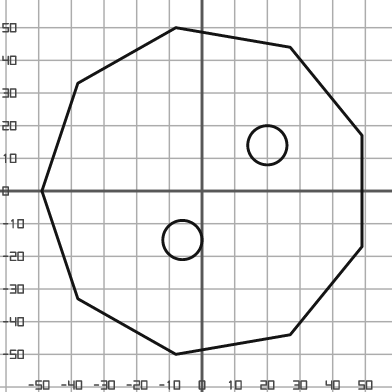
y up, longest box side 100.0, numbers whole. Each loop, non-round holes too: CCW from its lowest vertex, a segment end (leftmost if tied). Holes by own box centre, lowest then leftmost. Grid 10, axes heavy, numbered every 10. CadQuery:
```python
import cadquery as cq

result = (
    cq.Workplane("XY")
    .moveTo(-8.0, -50.0)
    .lineTo(27.0, -44.0)
    .lineTo(49.0, -17.0)
    .lineTo(49.0, 17.0)
    .lineTo(27.0, 44.0)
    .lineTo(-8.0, 50.0)
    .lineTo(-38.0, 33.0)
    .lineTo(-49.0, 0.0)
    .lineTo(-38.0, -33.0)
    .close()
    .moveTo(-6.0, -15.0)
    .circle(6.0)
    .moveTo(20.0, 14.0)
    .circle(6.0)
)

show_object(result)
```